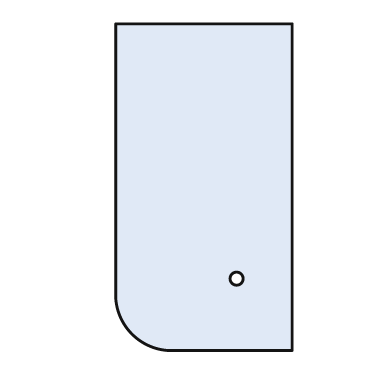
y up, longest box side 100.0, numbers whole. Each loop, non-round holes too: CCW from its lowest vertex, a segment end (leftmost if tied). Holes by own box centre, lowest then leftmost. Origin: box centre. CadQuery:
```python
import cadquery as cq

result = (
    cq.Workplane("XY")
    .moveTo(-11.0, -50.0)
    .lineTo(27.0, -50.0)
    .lineTo(27.0, 50.0)
    .lineTo(-27.0, 50.0)
    .lineTo(-27.0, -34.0)
    .threePointArc((-22.0, -45.0), (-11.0, -50.0))
    .close()
    .moveTo(10.0, -28.0)
    .circle(2.0)
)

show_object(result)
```